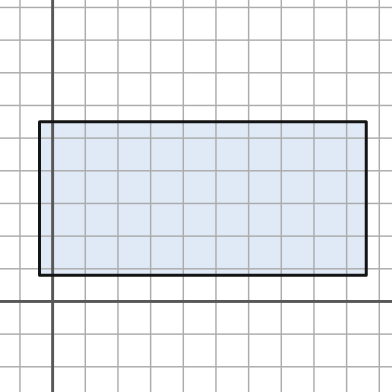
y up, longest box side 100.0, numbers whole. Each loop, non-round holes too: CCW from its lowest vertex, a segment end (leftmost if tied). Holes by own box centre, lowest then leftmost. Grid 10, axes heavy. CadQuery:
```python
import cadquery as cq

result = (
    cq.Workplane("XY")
    .moveTo(-4.0, 8.0)
    .lineTo(96.0, 8.0)
    .lineTo(96.0, 55.0)
    .lineTo(-4.0, 55.0)
    .close()
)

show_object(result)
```